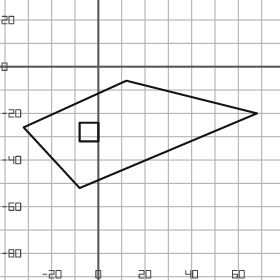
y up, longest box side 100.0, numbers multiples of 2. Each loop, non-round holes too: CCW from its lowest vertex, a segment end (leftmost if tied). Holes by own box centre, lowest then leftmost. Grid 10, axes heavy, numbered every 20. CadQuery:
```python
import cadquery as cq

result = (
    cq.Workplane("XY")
    .moveTo(-8.0, -52.0)
    .lineTo(68.0, -20.0)
    .lineTo(12.0, -6.0)
    .lineTo(-32.0, -26.0)
    .close()
    .moveTo(-8.0, -32.0)
    .lineTo(0.0, -32.0)
    .lineTo(0.0, -24.0)
    .lineTo(-8.0, -24.0)
    .close()
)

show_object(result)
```